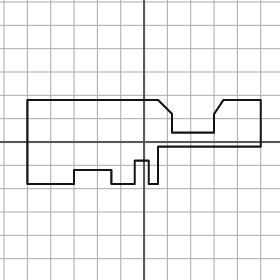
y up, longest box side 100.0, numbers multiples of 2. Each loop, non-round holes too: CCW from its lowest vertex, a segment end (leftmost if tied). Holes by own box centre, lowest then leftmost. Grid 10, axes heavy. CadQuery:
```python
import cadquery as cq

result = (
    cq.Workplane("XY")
    .moveTo(-50.0, -18.0)
    .lineTo(-30.0, -18.0)
    .lineTo(-30.0, -12.0)
    .lineTo(-14.0, -12.0)
    .lineTo(-14.0, -18.0)
    .lineTo(-4.0, -18.0)
    .lineTo(-4.0, -8.0)
    .lineTo(2.0, -8.0)
    .lineTo(2.0, -18.0)
    .lineTo(6.0, -18.0)
    .lineTo(6.0, -2.0)
    .lineTo(50.0, -2.0)
    .lineTo(50.0, 18.0)
    .lineTo(34.0, 18.0)
    .lineTo(30.0, 12.0)
    .lineTo(30.0, 4.0)
    .lineTo(12.0, 4.0)
    .lineTo(12.0, 12.0)
    .lineTo(6.0, 18.0)
    .lineTo(-50.0, 18.0)
    .close()
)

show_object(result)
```